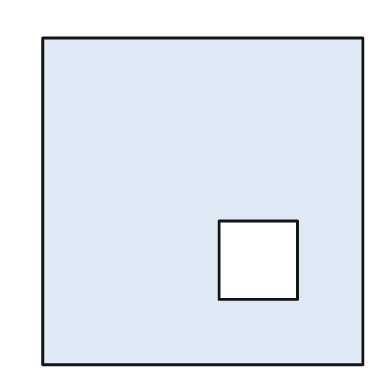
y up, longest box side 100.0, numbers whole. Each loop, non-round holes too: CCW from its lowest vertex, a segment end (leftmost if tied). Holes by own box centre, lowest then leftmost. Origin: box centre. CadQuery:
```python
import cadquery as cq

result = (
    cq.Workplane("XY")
    .moveTo(-49.0, -50.0)
    .lineTo(49.0, -50.0)
    .lineTo(49.0, 50.0)
    .lineTo(-49.0, 50.0)
    .close()
    .moveTo(5.0, -30.0)
    .lineTo(29.0, -30.0)
    .lineTo(29.0, -6.0)
    .lineTo(5.0, -6.0)
    .close()
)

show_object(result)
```